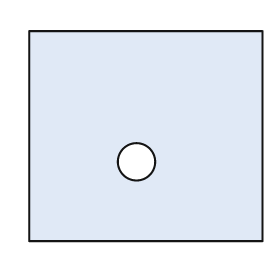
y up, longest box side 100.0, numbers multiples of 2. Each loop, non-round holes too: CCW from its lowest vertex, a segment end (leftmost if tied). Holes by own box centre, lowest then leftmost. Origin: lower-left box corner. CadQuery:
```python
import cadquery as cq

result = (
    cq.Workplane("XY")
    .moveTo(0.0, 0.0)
    .lineTo(100.0, 0.0)
    .lineTo(100.0, 90.0)
    .lineTo(0.0, 90.0)
    .close()
    .moveTo(46.0, 34.0)
    .circle(8.0)
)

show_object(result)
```